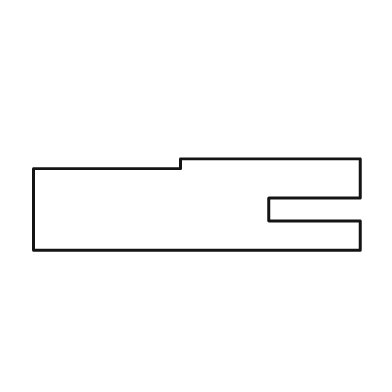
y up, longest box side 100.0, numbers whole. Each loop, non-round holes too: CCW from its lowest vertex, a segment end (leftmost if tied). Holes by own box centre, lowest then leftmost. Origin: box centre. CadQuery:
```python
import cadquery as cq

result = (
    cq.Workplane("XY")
    .moveTo(-50.0, -14.0)
    .lineTo(50.0, -14.0)
    .lineTo(50.0, -5.0)
    .lineTo(22.0, -5.0)
    .lineTo(22.0, 2.0)
    .lineTo(50.0, 2.0)
    .lineTo(50.0, 14.0)
    .lineTo(-5.0, 14.0)
    .lineTo(-5.0, 11.0)
    .lineTo(-50.0, 11.0)
    .close()
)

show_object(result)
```